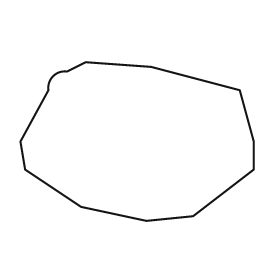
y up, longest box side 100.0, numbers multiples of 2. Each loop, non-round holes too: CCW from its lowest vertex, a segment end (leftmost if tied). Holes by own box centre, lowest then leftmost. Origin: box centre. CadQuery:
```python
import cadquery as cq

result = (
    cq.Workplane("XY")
    .moveTo(4.0, -34.0)
    .lineTo(24.0, -32.0)
    .lineTo(50.0, -12.0)
    .lineTo(50.0, 0.0)
    .lineTo(44.0, 22.0)
    .lineTo(6.0, 32.0)
    .lineTo(-22.0, 34.0)
    .lineTo(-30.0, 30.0)
    .threePointArc((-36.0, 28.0), (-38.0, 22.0))
    .lineTo(-50.0, 0.0)
    .lineTo(-48.0, -12.0)
    .lineTo(-24.0, -28.0)
    .close()
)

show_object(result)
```